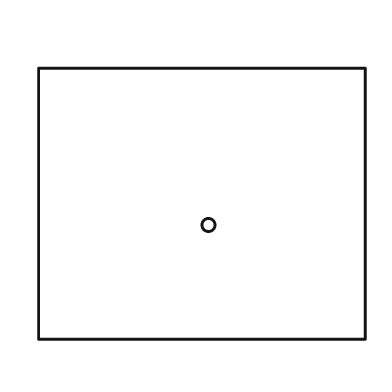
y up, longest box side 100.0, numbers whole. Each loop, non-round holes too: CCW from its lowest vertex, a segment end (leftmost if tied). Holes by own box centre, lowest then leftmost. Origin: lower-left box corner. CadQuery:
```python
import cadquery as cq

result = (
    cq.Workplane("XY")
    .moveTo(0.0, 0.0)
    .lineTo(100.0, 0.0)
    .lineTo(100.0, 83.0)
    .lineTo(0.0, 83.0)
    .close()
    .moveTo(52.0, 35.0)
    .circle(2.0)
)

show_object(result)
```